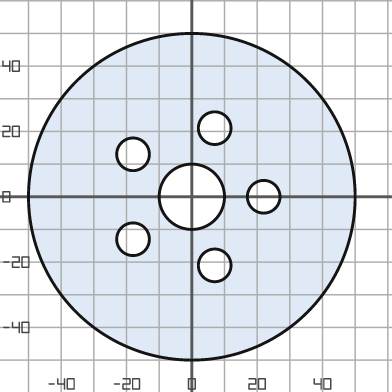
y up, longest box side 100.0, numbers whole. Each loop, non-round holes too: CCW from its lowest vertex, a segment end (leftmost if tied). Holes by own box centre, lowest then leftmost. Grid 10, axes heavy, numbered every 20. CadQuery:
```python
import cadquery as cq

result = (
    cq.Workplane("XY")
    .moveTo(0.0, 0.0)
    .circle(50.0)
    .moveTo(7.0, -21.0)
    .circle(5.0)
    .moveTo(-18.0, -13.0)
    .circle(5.0)
    .moveTo(0.0, 0.0)
    .circle(10.0)
    .moveTo(22.0, 0.0)
    .circle(5.0)
    .moveTo(-18.0, 13.0)
    .circle(5.0)
    .moveTo(7.0, 21.0)
    .circle(5.0)
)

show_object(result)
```